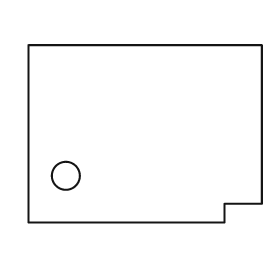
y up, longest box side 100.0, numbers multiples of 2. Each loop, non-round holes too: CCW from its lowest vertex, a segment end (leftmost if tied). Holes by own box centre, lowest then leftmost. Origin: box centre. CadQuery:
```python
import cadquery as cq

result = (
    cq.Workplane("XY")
    .moveTo(-50.0, -38.0)
    .lineTo(34.0, -38.0)
    .lineTo(34.0, -30.0)
    .lineTo(50.0, -30.0)
    .lineTo(50.0, 38.0)
    .lineTo(-50.0, 38.0)
    .close()
    .moveTo(-34.0, -18.0)
    .circle(6.0)
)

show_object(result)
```